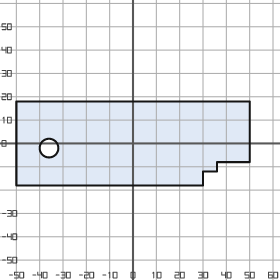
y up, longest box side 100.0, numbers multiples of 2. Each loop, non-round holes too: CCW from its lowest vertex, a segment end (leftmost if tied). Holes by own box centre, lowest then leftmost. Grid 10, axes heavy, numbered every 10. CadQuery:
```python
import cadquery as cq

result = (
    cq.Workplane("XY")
    .moveTo(-50.0, -18.0)
    .lineTo(30.0, -18.0)
    .lineTo(30.0, -12.0)
    .lineTo(36.0, -12.0)
    .lineTo(36.0, -8.0)
    .lineTo(50.0, -8.0)
    .lineTo(50.0, 18.0)
    .lineTo(-50.0, 18.0)
    .close()
    .moveTo(-36.0, -2.0)
    .circle(4.0)
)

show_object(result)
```